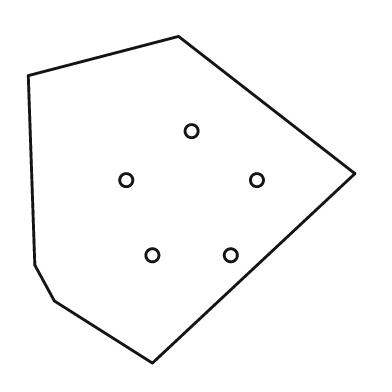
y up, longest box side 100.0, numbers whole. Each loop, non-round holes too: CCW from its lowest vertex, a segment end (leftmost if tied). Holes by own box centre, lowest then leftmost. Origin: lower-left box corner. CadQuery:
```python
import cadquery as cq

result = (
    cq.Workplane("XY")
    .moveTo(38.0, 0.0)
    .lineTo(100.0, 58.0)
    .lineTo(46.0, 100.0)
    .lineTo(0.0, 88.0)
    .lineTo(2.0, 30.0)
    .lineTo(8.0, 19.0)
    .close()
    .moveTo(38.0, 33.0)
    .circle(2.0)
    .moveTo(62.0, 33.0)
    .circle(2.0)
    .moveTo(30.0, 56.0)
    .circle(2.0)
    .moveTo(70.0, 56.0)
    .circle(2.0)
    .moveTo(50.0, 71.0)
    .circle(2.0)
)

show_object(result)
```